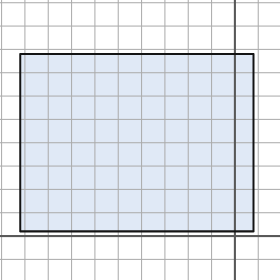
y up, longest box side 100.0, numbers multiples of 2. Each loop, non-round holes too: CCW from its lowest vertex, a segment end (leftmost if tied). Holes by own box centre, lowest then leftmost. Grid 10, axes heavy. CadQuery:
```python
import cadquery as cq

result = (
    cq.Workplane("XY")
    .moveTo(-92.0, 2.0)
    .lineTo(8.0, 2.0)
    .lineTo(8.0, 78.0)
    .lineTo(-92.0, 78.0)
    .close()
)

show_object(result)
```